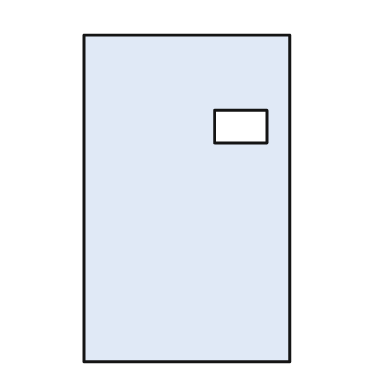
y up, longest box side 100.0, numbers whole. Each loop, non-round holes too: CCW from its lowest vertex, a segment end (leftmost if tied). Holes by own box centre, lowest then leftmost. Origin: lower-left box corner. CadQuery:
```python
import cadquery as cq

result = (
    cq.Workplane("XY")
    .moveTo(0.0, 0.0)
    .lineTo(63.0, 0.0)
    .lineTo(63.0, 100.0)
    .lineTo(0.0, 100.0)
    .close()
    .moveTo(40.0, 67.0)
    .lineTo(56.0, 67.0)
    .lineTo(56.0, 77.0)
    .lineTo(40.0, 77.0)
    .close()
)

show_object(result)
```